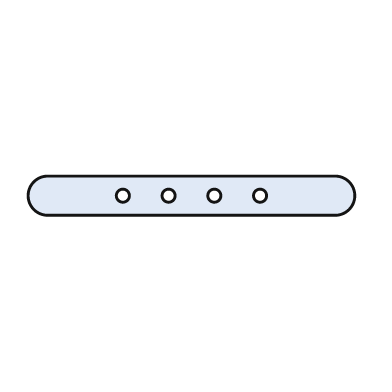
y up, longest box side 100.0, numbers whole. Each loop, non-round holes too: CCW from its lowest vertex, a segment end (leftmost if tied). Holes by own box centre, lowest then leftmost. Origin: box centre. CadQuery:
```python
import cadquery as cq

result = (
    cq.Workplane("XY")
    .moveTo(-44.0, -6.0)
    .lineTo(44.0, -6.0)
    .threePointArc((50.0, 0.0), (44.0, 6.0))
    .lineTo(-44.0, 6.0)
    .threePointArc((-50.0, 0.0), (-44.0, -6.0))
    .close()
    .moveTo(-21.0, 0.0)
    .circle(2.0)
    .moveTo(-7.0, 0.0)
    .circle(2.0)
    .moveTo(7.0, 0.0)
    .circle(2.0)
    .moveTo(21.0, 0.0)
    .circle(2.0)
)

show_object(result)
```